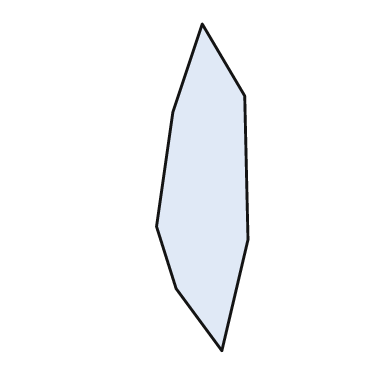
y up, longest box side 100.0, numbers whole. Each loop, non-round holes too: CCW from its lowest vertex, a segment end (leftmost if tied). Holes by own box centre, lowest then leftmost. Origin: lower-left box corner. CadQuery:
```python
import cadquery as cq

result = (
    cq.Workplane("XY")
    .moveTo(20.0, 0.0)
    .lineTo(28.0, 34.0)
    .lineTo(27.0, 78.0)
    .lineTo(14.0, 100.0)
    .lineTo(5.0, 73.0)
    .lineTo(0.0, 38.0)
    .lineTo(6.0, 19.0)
    .close()
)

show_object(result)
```